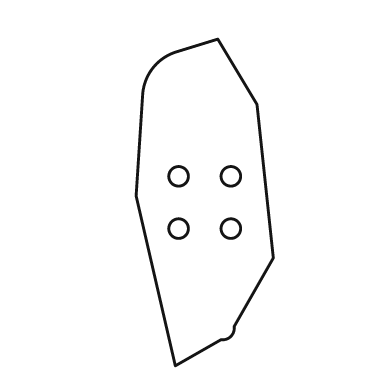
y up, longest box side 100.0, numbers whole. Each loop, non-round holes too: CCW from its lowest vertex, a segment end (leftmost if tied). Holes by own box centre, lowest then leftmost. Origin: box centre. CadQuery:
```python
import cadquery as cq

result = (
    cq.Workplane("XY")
    .moveTo(-9.0, -50.0)
    .lineTo(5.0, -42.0)
    .threePointArc((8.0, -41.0), (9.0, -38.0))
    .lineTo(21.0, -17.0)
    .lineTo(16.0, 30.0)
    .lineTo(4.0, 50.0)
    .lineTo(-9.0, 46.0)
    .threePointArc((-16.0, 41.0), (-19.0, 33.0))
    .lineTo(-21.0, 2.0)
    .close()
    .moveTo(-8.0, -8.0)
    .circle(3.0)
    .moveTo(8.0, -8.0)
    .circle(3.0)
    .moveTo(-8.0, 8.0)
    .circle(3.0)
    .moveTo(8.0, 8.0)
    .circle(3.0)
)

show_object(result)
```